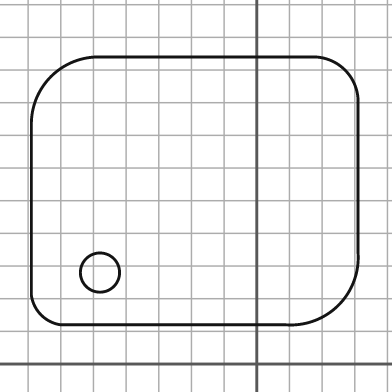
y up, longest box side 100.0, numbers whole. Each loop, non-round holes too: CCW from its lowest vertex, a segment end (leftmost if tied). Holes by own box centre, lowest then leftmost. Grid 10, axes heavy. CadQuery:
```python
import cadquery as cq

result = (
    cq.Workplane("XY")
    .moveTo(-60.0, 12.0)
    .lineTo(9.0, 12.0)
    .threePointArc((25.0, 18.0), (31.0, 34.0))
    .lineTo(31.0, 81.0)
    .threePointArc((27.0, 90.0), (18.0, 94.0))
    .lineTo(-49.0, 94.0)
    .threePointArc((-63.0, 88.0), (-69.0, 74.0))
    .lineTo(-69.0, 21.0)
    .threePointArc((-66.0, 15.0), (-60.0, 12.0))
    .close()
    .moveTo(-48.0, 28.0)
    .circle(6.0)
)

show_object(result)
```